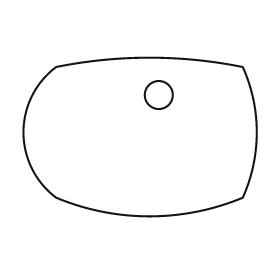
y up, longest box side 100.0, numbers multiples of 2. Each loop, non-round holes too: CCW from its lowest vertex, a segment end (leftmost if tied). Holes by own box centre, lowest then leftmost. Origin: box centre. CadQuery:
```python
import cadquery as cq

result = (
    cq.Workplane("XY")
    .moveTo(-36.0, -26.0)
    .threePointArc((4.0, -34.0), (44.0, -26.0))
    .threePointArc((50.0, 2.0), (44.0, 30.0))
    .threePointArc((4.0, 34.0), (-36.0, 30.0))
    .threePointArc((-50.0, 2.0), (-36.0, -26.0))
    .close()
    .moveTo(8.0, 18.0)
    .circle(6.0)
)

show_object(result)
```